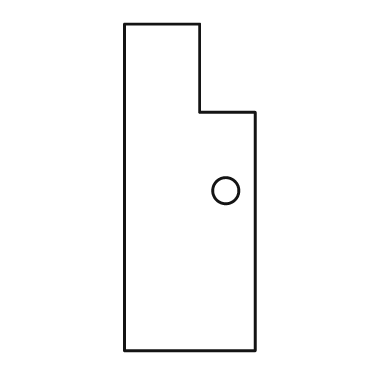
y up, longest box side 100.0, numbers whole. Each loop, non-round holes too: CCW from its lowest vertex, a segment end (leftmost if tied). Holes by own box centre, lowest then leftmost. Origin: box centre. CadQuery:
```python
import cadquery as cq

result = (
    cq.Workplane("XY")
    .moveTo(-20.0, -50.0)
    .lineTo(20.0, -50.0)
    .lineTo(20.0, 23.0)
    .lineTo(3.0, 23.0)
    .lineTo(3.0, 50.0)
    .lineTo(-20.0, 50.0)
    .close()
    .moveTo(11.0, -1.0)
    .circle(4.0)
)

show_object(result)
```